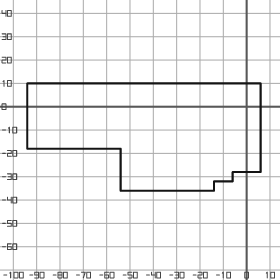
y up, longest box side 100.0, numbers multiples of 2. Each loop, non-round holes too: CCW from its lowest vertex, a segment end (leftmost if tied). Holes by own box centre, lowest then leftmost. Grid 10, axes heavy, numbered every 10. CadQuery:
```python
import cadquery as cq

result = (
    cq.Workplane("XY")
    .moveTo(-54.0, -36.0)
    .lineTo(-14.0, -36.0)
    .lineTo(-14.0, -32.0)
    .lineTo(-6.0, -32.0)
    .lineTo(-6.0, -28.0)
    .lineTo(6.0, -28.0)
    .lineTo(6.0, 10.0)
    .lineTo(-94.0, 10.0)
    .lineTo(-94.0, -18.0)
    .lineTo(-54.0, -18.0)
    .close()
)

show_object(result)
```